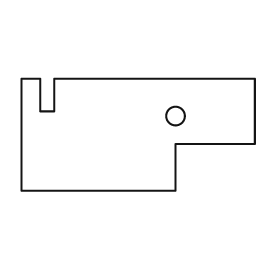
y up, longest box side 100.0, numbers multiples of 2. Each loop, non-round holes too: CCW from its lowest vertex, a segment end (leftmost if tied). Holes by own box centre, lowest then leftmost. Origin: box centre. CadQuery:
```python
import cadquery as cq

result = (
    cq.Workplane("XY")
    .moveTo(-50.0, -24.0)
    .lineTo(16.0, -24.0)
    .lineTo(16.0, -4.0)
    .lineTo(50.0, -4.0)
    .lineTo(50.0, 24.0)
    .lineTo(-36.0, 24.0)
    .lineTo(-36.0, 10.0)
    .lineTo(-42.0, 10.0)
    .lineTo(-42.0, 24.0)
    .lineTo(-50.0, 24.0)
    .close()
    .moveTo(16.0, 8.0)
    .circle(4.0)
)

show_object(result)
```